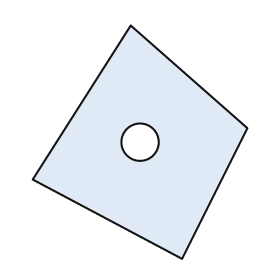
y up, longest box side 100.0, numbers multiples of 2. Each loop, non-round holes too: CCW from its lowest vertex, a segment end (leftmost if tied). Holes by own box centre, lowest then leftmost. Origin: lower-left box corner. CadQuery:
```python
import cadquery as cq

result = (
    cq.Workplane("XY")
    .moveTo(64.0, 0.0)
    .lineTo(92.0, 56.0)
    .lineTo(42.0, 100.0)
    .lineTo(0.0, 34.0)
    .close()
    .moveTo(46.0, 50.0)
    .circle(8.0)
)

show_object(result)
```